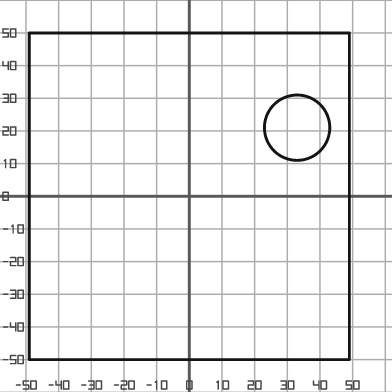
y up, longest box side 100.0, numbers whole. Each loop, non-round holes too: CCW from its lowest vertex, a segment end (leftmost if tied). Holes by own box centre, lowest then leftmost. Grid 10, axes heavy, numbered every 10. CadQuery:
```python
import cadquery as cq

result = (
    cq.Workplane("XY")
    .moveTo(-49.0, -50.0)
    .lineTo(49.0, -50.0)
    .lineTo(49.0, 50.0)
    .lineTo(-49.0, 50.0)
    .close()
    .moveTo(33.0, 21.0)
    .circle(10.0)
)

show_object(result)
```